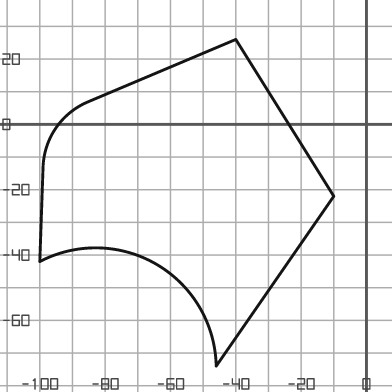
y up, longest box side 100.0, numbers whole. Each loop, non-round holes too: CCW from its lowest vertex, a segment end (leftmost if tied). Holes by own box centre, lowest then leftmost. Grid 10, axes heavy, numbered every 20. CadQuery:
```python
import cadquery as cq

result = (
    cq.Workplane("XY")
    .moveTo(-46.0, -74.0)
    .lineTo(-10.0, -22.0)
    .lineTo(-40.0, 26.0)
    .lineTo(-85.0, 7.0)
    .threePointArc((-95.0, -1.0), (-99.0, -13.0))
    .lineTo(-100.0, -42.0)
    .threePointArc((-64.0, -43.0), (-46.0, -74.0))
    .close()
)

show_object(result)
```